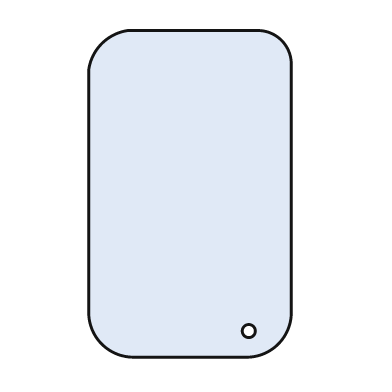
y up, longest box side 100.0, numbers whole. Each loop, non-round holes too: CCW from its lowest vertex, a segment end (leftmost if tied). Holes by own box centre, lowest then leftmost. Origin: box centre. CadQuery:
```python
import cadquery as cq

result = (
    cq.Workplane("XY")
    .moveTo(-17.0, -50.0)
    .lineTo(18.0, -50.0)
    .threePointArc((27.0, -46.0), (31.0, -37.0))
    .lineTo(31.0, 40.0)
    .threePointArc((28.0, 47.0), (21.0, 50.0))
    .lineTo(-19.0, 50.0)
    .threePointArc((-27.0, 46.0), (-31.0, 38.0))
    .lineTo(-31.0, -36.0)
    .threePointArc((-27.0, -46.0), (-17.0, -50.0))
    .close()
    .moveTo(18.0, -42.0)
    .circle(2.0)
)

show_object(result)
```